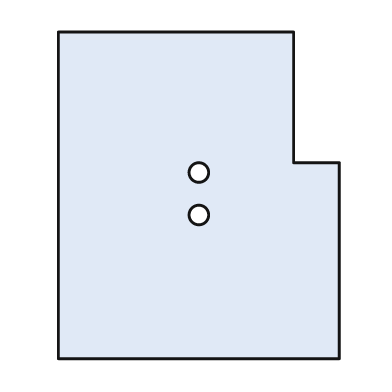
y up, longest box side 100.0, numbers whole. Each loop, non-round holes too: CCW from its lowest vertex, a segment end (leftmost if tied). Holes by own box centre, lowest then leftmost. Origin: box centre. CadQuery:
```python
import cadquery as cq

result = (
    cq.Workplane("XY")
    .moveTo(-43.0, -50.0)
    .lineTo(43.0, -50.0)
    .lineTo(43.0, 10.0)
    .lineTo(29.0, 10.0)
    .lineTo(29.0, 50.0)
    .lineTo(-43.0, 50.0)
    .close()
    .moveTo(0.0, -6.0)
    .circle(3.0)
    .moveTo(0.0, 7.0)
    .circle(3.0)
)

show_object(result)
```